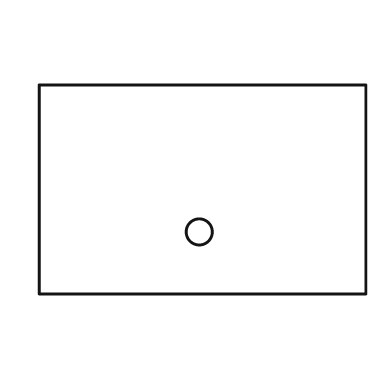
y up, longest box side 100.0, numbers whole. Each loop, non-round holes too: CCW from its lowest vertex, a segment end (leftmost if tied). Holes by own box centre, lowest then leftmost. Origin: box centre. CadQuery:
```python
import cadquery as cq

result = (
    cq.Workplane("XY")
    .moveTo(-50.0, -32.0)
    .lineTo(50.0, -32.0)
    .lineTo(50.0, 32.0)
    .lineTo(-50.0, 32.0)
    .close()
    .moveTo(-1.0, -13.0)
    .circle(4.0)
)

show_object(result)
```